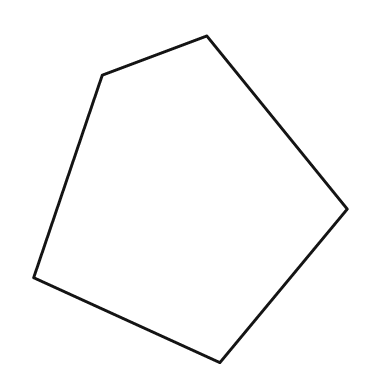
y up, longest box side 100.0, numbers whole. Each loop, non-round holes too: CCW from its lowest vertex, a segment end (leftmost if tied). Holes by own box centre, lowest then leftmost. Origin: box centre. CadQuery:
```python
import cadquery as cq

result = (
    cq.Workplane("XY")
    .moveTo(9.0, -50.0)
    .lineTo(48.0, -3.0)
    .lineTo(5.0, 50.0)
    .lineTo(-27.0, 38.0)
    .lineTo(-48.0, -24.0)
    .close()
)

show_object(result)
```